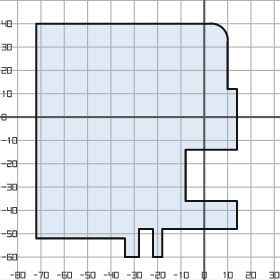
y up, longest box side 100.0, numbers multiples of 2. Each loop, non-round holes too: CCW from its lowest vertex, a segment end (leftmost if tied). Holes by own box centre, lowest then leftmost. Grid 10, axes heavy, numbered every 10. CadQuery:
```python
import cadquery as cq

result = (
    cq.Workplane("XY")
    .moveTo(-34.0, -60.0)
    .lineTo(-28.0, -60.0)
    .lineTo(-28.0, -48.0)
    .lineTo(-22.0, -48.0)
    .lineTo(-22.0, -60.0)
    .lineTo(-18.0, -60.0)
    .lineTo(-18.0, -48.0)
    .lineTo(14.0, -48.0)
    .lineTo(14.0, -36.0)
    .lineTo(-8.0, -36.0)
    .lineTo(-8.0, -14.0)
    .lineTo(14.0, -14.0)
    .lineTo(14.0, 12.0)
    .lineTo(10.0, 12.0)
    .lineTo(10.0, 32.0)
    .threePointArc((8.0, 38.0), (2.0, 40.0))
    .lineTo(-72.0, 40.0)
    .lineTo(-72.0, -52.0)
    .lineTo(-34.0, -52.0)
    .close()
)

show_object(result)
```